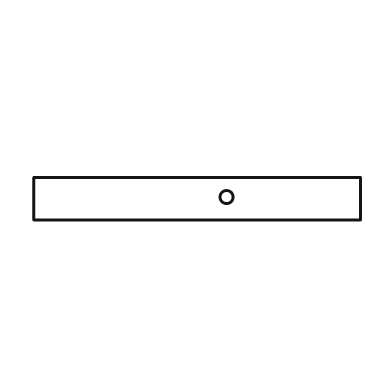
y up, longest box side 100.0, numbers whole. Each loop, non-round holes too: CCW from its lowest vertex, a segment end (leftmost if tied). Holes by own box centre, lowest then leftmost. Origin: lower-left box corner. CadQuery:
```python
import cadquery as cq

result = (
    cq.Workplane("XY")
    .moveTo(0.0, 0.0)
    .lineTo(100.0, 0.0)
    .lineTo(100.0, 13.0)
    .lineTo(0.0, 13.0)
    .close()
    .moveTo(59.0, 7.0)
    .circle(2.0)
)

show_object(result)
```